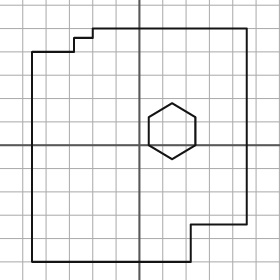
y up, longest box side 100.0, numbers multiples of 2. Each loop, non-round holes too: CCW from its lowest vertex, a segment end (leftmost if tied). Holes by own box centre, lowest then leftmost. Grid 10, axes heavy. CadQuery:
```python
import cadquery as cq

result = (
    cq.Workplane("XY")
    .moveTo(-46.0, -50.0)
    .lineTo(22.0, -50.0)
    .lineTo(22.0, -34.0)
    .lineTo(46.0, -34.0)
    .lineTo(46.0, 50.0)
    .lineTo(-20.0, 50.0)
    .lineTo(-20.0, 46.0)
    .lineTo(-28.0, 46.0)
    .lineTo(-28.0, 40.0)
    .lineTo(-46.0, 40.0)
    .close()
    .moveTo(14.0, -6.0)
    .lineTo(24.0, 0.0)
    .lineTo(24.0, 12.0)
    .lineTo(14.0, 18.0)
    .lineTo(4.0, 12.0)
    .lineTo(4.0, 0.0)
    .close()
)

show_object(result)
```